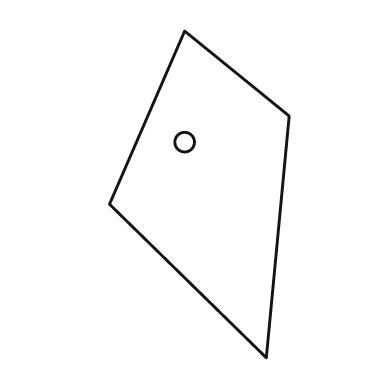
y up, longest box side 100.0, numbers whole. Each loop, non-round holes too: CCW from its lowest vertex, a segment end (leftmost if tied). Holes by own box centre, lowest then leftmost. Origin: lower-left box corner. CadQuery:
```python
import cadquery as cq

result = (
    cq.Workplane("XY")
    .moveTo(48.0, 0.0)
    .lineTo(55.0, 74.0)
    .lineTo(23.0, 100.0)
    .lineTo(0.0, 47.0)
    .close()
    .moveTo(23.0, 66.0)
    .circle(3.0)
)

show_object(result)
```